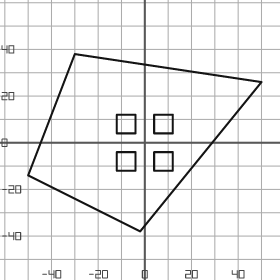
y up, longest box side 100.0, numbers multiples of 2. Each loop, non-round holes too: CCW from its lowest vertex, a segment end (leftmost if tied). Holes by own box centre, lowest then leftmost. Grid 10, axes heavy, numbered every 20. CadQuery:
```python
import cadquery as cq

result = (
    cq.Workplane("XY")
    .moveTo(-2.0, -38.0)
    .lineTo(50.0, 26.0)
    .lineTo(-30.0, 38.0)
    .lineTo(-50.0, -14.0)
    .close()
    .moveTo(-12.0, -12.0)
    .lineTo(-4.0, -12.0)
    .lineTo(-4.0, -4.0)
    .lineTo(-12.0, -4.0)
    .close()
    .moveTo(4.0, -12.0)
    .lineTo(12.0, -12.0)
    .lineTo(12.0, -4.0)
    .lineTo(4.0, -4.0)
    .close()
    .moveTo(-12.0, 4.0)
    .lineTo(-4.0, 4.0)
    .lineTo(-4.0, 12.0)
    .lineTo(-12.0, 12.0)
    .close()
    .moveTo(4.0, 4.0)
    .lineTo(12.0, 4.0)
    .lineTo(12.0, 12.0)
    .lineTo(4.0, 12.0)
    .close()
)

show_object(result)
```